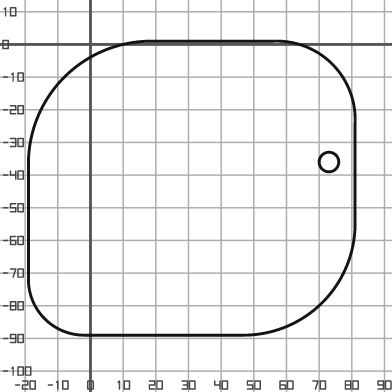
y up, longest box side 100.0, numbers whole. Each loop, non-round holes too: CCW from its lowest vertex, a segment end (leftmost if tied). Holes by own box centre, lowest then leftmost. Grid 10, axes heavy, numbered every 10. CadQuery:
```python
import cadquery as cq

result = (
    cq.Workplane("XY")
    .moveTo(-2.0, -89.0)
    .lineTo(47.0, -89.0)
    .threePointArc((71.0, -79.0), (81.0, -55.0))
    .lineTo(81.0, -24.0)
    .threePointArc((74.0, -6.0), (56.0, 1.0))
    .lineTo(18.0, 1.0)
    .threePointArc((-8.0, -10.0), (-19.0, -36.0))
    .lineTo(-19.0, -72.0)
    .threePointArc((-14.0, -84.0), (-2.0, -89.0))
    .close()
    .moveTo(73.0, -36.0)
    .circle(3.0)
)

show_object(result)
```